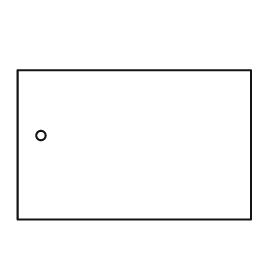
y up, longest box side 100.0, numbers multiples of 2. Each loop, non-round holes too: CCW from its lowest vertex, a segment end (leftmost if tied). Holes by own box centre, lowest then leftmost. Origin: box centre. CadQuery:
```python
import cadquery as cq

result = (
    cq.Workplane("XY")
    .moveTo(-50.0, -32.0)
    .lineTo(50.0, -32.0)
    .lineTo(50.0, 32.0)
    .lineTo(-50.0, 32.0)
    .close()
    .moveTo(-40.0, 4.0)
    .circle(2.0)
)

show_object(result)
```